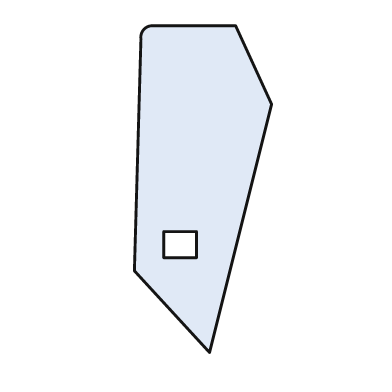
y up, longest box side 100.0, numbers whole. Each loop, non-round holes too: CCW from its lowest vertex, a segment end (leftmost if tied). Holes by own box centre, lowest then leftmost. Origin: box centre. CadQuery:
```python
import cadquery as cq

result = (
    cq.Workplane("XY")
    .moveTo(2.0, -50.0)
    .lineTo(21.0, 26.0)
    .lineTo(10.0, 50.0)
    .lineTo(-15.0, 50.0)
    .threePointArc((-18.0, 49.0), (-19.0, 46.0))
    .lineTo(-21.0, -25.0)
    .close()
    .moveTo(-12.0, -21.0)
    .lineTo(-2.0, -21.0)
    .lineTo(-2.0, -13.0)
    .lineTo(-12.0, -13.0)
    .close()
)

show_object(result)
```